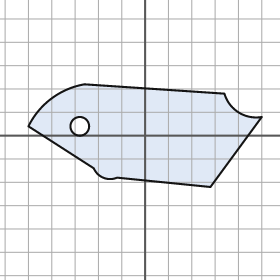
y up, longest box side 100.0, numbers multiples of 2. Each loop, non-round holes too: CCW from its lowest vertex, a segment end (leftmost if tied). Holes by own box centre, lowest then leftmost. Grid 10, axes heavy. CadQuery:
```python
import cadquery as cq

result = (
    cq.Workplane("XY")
    .moveTo(28.0, -22.0)
    .lineTo(50.0, 8.0)
    .threePointArc((40.0, 10.0), (34.0, 18.0))
    .lineTo(-26.0, 22.0)
    .threePointArc((-40.0, 16.0), (-50.0, 4.0))
    .lineTo(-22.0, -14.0)
    .threePointArc((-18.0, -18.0), (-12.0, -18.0))
    .close()
    .moveTo(-28.0, 4.0)
    .circle(4.0)
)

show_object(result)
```